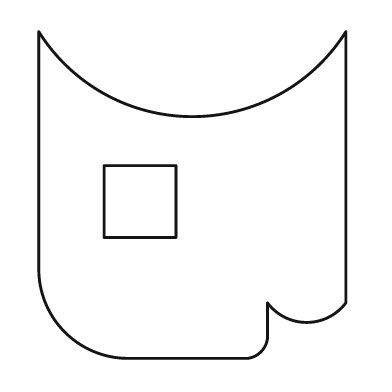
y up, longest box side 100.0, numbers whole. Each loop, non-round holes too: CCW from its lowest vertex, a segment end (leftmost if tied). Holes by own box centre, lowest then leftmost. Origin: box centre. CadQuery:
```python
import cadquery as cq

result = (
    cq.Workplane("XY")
    .moveTo(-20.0, -50.0)
    .lineTo(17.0, -50.0)
    .threePointArc((21.0, -48.0), (23.0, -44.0))
    .lineTo(23.0, -33.0)
    .threePointArc((35.0, -39.0), (47.0, -33.0))
    .lineTo(47.0, 50.0)
    .threePointArc((0.0, 24.0), (-47.0, 50.0))
    .lineTo(-47.0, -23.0)
    .threePointArc((-39.0, -42.0), (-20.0, -50.0))
    .close()
    .moveTo(-27.0, -13.0)
    .lineTo(-5.0, -13.0)
    .lineTo(-5.0, 9.0)
    .lineTo(-27.0, 9.0)
    .close()
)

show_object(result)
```